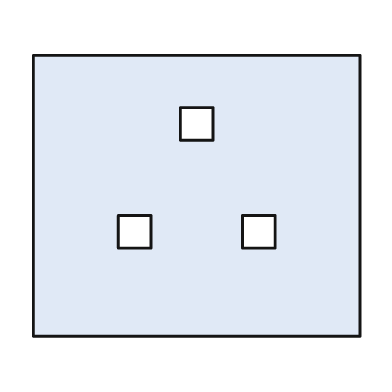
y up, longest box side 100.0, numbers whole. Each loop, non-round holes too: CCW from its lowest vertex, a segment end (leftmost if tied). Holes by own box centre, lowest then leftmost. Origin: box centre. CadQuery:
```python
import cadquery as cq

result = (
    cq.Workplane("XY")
    .moveTo(-50.0, -43.0)
    .lineTo(50.0, -43.0)
    .lineTo(50.0, 43.0)
    .lineTo(-50.0, 43.0)
    .close()
    .moveTo(-24.0, -16.0)
    .lineTo(-14.0, -16.0)
    .lineTo(-14.0, -6.0)
    .lineTo(-24.0, -6.0)
    .close()
    .moveTo(14.0, -16.0)
    .lineTo(24.0, -16.0)
    .lineTo(24.0, -6.0)
    .lineTo(14.0, -6.0)
    .close()
    .moveTo(-5.0, 17.0)
    .lineTo(5.0, 17.0)
    .lineTo(5.0, 27.0)
    .lineTo(-5.0, 27.0)
    .close()
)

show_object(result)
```